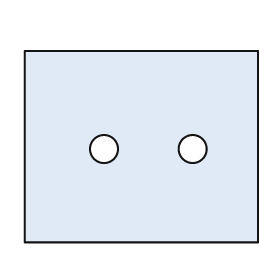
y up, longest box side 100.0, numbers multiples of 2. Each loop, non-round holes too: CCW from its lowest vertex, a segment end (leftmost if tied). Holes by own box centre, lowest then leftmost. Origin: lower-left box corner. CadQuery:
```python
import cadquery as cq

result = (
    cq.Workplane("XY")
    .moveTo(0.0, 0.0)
    .lineTo(100.0, 0.0)
    .lineTo(100.0, 82.0)
    .lineTo(0.0, 82.0)
    .close()
    .moveTo(34.0, 40.0)
    .circle(6.0)
    .moveTo(72.0, 40.0)
    .circle(6.0)
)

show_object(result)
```